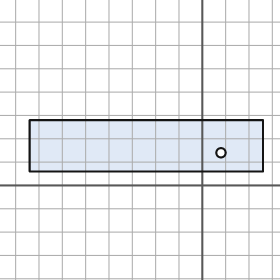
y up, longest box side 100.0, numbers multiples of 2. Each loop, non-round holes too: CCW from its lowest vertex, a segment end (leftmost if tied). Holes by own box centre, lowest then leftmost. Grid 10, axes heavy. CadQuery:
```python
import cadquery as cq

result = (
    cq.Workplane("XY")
    .moveTo(-74.0, 6.0)
    .lineTo(26.0, 6.0)
    .lineTo(26.0, 28.0)
    .lineTo(-74.0, 28.0)
    .close()
    .moveTo(8.0, 14.0)
    .circle(2.0)
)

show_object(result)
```